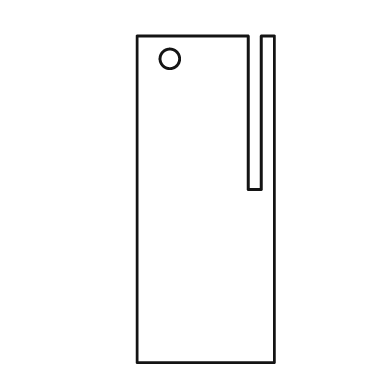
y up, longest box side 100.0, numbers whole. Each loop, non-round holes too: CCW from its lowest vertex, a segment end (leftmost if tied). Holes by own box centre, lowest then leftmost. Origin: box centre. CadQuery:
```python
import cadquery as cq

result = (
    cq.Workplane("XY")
    .moveTo(-21.0, -50.0)
    .lineTo(21.0, -50.0)
    .lineTo(21.0, 50.0)
    .lineTo(17.0, 50.0)
    .lineTo(17.0, 3.0)
    .lineTo(13.0, 3.0)
    .lineTo(13.0, 50.0)
    .lineTo(-21.0, 50.0)
    .close()
    .moveTo(-11.0, 43.0)
    .circle(3.0)
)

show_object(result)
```